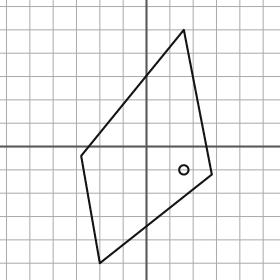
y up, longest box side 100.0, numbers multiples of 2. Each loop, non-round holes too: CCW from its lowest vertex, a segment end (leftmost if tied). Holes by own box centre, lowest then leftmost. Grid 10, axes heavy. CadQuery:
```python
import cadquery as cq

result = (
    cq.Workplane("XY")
    .moveTo(-20.0, -50.0)
    .lineTo(28.0, -12.0)
    .lineTo(16.0, 50.0)
    .lineTo(-28.0, -4.0)
    .close()
    .moveTo(16.0, -10.0)
    .circle(2.0)
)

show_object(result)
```